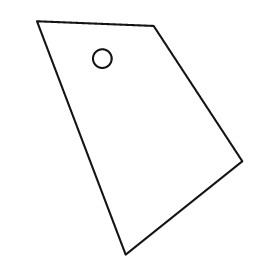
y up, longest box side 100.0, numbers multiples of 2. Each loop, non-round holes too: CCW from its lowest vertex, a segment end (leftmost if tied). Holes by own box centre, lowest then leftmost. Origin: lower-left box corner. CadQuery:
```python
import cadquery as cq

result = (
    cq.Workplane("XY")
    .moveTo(38.0, 0.0)
    .lineTo(88.0, 40.0)
    .lineTo(50.0, 98.0)
    .lineTo(0.0, 100.0)
    .close()
    .moveTo(28.0, 84.0)
    .circle(4.0)
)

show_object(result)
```